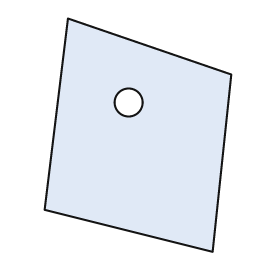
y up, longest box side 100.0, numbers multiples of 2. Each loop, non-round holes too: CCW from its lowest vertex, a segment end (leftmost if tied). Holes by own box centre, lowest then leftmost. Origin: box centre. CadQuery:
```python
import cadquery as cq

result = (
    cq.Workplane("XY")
    .moveTo(32.0, -50.0)
    .lineTo(40.0, 26.0)
    .lineTo(-30.0, 50.0)
    .lineTo(-40.0, -32.0)
    .close()
    .moveTo(-4.0, 14.0)
    .circle(6.0)
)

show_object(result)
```